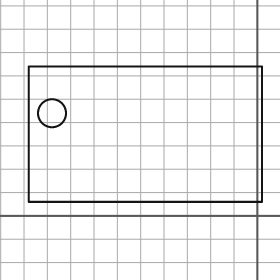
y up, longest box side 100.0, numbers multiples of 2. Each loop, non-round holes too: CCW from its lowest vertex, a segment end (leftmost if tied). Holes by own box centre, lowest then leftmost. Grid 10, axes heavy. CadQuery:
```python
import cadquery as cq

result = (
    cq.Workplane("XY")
    .moveTo(-98.0, 6.0)
    .lineTo(2.0, 6.0)
    .lineTo(2.0, 64.0)
    .lineTo(-98.0, 64.0)
    .close()
    .moveTo(-88.0, 44.0)
    .circle(6.0)
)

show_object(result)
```